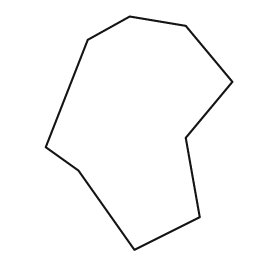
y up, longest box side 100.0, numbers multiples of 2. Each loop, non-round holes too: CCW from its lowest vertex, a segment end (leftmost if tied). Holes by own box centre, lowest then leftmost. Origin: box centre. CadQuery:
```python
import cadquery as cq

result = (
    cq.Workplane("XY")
    .moveTo(-2.0, -50.0)
    .lineTo(26.0, -36.0)
    .lineTo(20.0, -2.0)
    .lineTo(40.0, 22.0)
    .lineTo(20.0, 46.0)
    .lineTo(-4.0, 50.0)
    .lineTo(-22.0, 40.0)
    .lineTo(-40.0, -6.0)
    .lineTo(-26.0, -16.0)
    .close()
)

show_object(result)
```